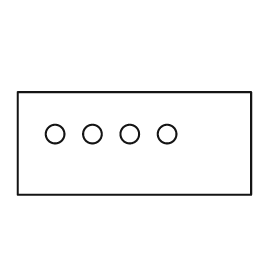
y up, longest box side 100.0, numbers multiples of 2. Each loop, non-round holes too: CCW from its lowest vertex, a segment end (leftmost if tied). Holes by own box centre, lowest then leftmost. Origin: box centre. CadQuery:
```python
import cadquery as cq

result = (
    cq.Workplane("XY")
    .moveTo(-50.0, -22.0)
    .lineTo(50.0, -22.0)
    .lineTo(50.0, 22.0)
    .lineTo(-50.0, 22.0)
    .close()
    .moveTo(-34.0, 4.0)
    .circle(4.0)
    .moveTo(-18.0, 4.0)
    .circle(4.0)
    .moveTo(-2.0, 4.0)
    .circle(4.0)
    .moveTo(14.0, 4.0)
    .circle(4.0)
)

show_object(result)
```